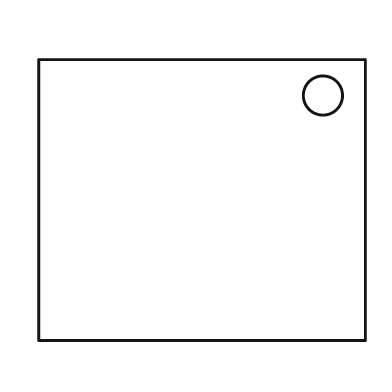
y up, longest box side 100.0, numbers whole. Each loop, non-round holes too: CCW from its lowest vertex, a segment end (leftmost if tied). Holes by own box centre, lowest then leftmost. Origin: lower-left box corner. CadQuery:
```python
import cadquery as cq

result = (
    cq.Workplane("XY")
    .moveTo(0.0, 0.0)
    .lineTo(100.0, 0.0)
    .lineTo(100.0, 86.0)
    .lineTo(0.0, 86.0)
    .close()
    .moveTo(87.0, 75.0)
    .circle(6.0)
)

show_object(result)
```